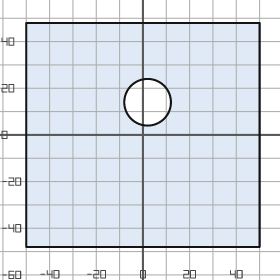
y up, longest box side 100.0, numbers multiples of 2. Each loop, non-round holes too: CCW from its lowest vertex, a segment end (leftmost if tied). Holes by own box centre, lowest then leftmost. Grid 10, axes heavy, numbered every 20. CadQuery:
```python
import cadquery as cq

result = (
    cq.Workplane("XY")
    .moveTo(-50.0, -48.0)
    .lineTo(50.0, -48.0)
    .lineTo(50.0, 48.0)
    .lineTo(-50.0, 48.0)
    .close()
    .moveTo(2.0, 14.0)
    .circle(10.0)
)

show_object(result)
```